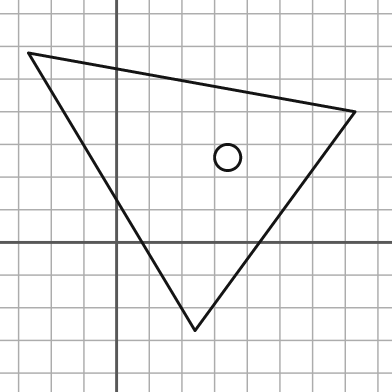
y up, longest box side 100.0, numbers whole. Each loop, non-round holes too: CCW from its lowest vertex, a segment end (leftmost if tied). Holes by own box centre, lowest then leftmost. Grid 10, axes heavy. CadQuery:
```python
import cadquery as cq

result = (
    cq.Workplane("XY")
    .moveTo(24.0, -27.0)
    .lineTo(73.0, 40.0)
    .lineTo(-27.0, 58.0)
    .close()
    .moveTo(34.0, 26.0)
    .circle(4.0)
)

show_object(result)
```